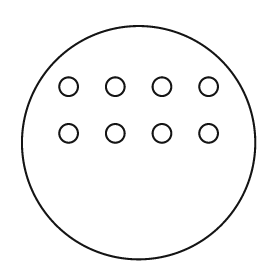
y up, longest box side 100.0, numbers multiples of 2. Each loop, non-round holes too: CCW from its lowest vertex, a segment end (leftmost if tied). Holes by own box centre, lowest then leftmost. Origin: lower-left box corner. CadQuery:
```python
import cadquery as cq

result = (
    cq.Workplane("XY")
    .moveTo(50.0, 50.0)
    .circle(50.0)
    .moveTo(20.0, 54.0)
    .circle(4.0)
    .moveTo(40.0, 54.0)
    .circle(4.0)
    .moveTo(60.0, 54.0)
    .circle(4.0)
    .moveTo(80.0, 54.0)
    .circle(4.0)
    .moveTo(20.0, 74.0)
    .circle(4.0)
    .moveTo(40.0, 74.0)
    .circle(4.0)
    .moveTo(60.0, 74.0)
    .circle(4.0)
    .moveTo(80.0, 74.0)
    .circle(4.0)
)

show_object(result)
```